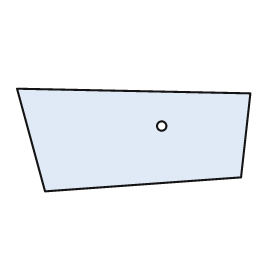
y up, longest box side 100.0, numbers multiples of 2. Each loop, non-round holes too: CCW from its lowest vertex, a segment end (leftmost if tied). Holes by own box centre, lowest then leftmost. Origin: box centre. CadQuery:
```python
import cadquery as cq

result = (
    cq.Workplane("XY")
    .moveTo(-38.0, -22.0)
    .lineTo(46.0, -16.0)
    .lineTo(50.0, 20.0)
    .lineTo(-50.0, 22.0)
    .close()
    .moveTo(12.0, 6.0)
    .circle(2.0)
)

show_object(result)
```